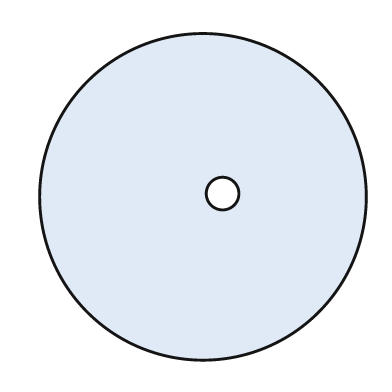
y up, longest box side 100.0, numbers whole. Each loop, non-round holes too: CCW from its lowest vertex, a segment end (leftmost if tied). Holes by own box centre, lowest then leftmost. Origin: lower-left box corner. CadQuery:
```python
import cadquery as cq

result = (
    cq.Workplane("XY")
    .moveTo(50.0, 50.0)
    .circle(50.0)
    .moveTo(56.0, 51.0)
    .circle(5.0)
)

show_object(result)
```